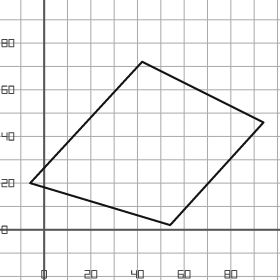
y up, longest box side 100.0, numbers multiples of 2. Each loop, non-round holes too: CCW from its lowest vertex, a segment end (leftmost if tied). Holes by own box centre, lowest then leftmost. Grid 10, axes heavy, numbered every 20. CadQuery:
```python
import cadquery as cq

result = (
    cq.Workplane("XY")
    .moveTo(54.0, 2.0)
    .lineTo(94.0, 46.0)
    .lineTo(42.0, 72.0)
    .lineTo(-6.0, 20.0)
    .close()
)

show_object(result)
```